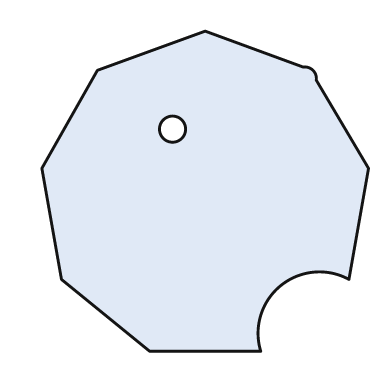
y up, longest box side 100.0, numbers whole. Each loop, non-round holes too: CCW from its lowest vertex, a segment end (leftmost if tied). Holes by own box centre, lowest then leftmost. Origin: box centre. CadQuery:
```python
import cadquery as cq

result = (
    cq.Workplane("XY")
    .moveTo(-17.0, -49.0)
    .lineTo(17.0, -49.0)
    .threePointArc((23.0, -29.0), (44.0, -27.0))
    .lineTo(50.0, 7.0)
    .lineTo(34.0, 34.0)
    .threePointArc((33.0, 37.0), (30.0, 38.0))
    .lineTo(0.0, 49.0)
    .lineTo(-33.0, 37.0)
    .lineTo(-50.0, 7.0)
    .lineTo(-44.0, -27.0)
    .close()
    .moveTo(-10.0, 19.0)
    .circle(4.0)
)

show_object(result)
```